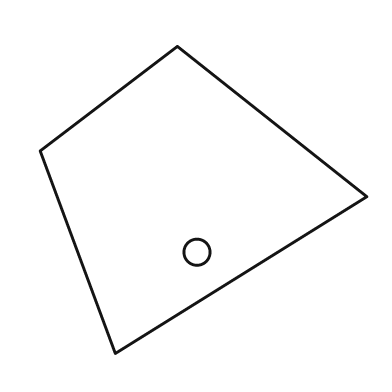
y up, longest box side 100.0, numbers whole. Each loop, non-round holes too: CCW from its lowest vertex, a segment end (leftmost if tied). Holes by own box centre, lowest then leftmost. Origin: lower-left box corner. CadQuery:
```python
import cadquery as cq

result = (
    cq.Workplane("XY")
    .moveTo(23.0, 0.0)
    .lineTo(100.0, 48.0)
    .lineTo(42.0, 94.0)
    .lineTo(0.0, 62.0)
    .close()
    .moveTo(48.0, 31.0)
    .circle(4.0)
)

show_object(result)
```